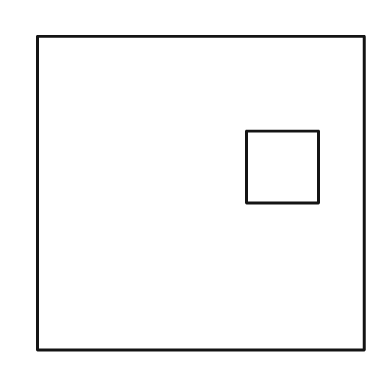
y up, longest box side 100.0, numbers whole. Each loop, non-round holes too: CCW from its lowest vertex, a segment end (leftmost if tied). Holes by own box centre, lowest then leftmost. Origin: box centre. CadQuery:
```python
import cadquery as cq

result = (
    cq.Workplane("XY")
    .moveTo(-50.0, -48.0)
    .lineTo(50.0, -48.0)
    .lineTo(50.0, 48.0)
    .lineTo(-50.0, 48.0)
    .close()
    .moveTo(14.0, -3.0)
    .lineTo(36.0, -3.0)
    .lineTo(36.0, 19.0)
    .lineTo(14.0, 19.0)
    .close()
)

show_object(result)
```